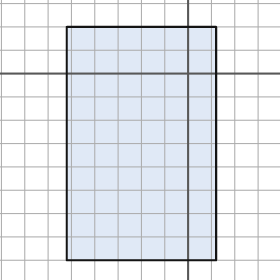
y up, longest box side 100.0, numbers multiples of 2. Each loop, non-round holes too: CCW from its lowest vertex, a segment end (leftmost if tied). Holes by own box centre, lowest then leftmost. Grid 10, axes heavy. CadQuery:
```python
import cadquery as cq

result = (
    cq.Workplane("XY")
    .moveTo(-52.0, -80.0)
    .lineTo(12.0, -80.0)
    .lineTo(12.0, 20.0)
    .lineTo(-52.0, 20.0)
    .close()
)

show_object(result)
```